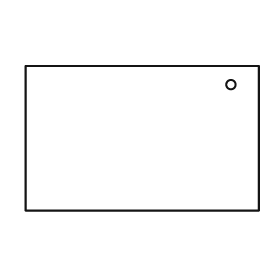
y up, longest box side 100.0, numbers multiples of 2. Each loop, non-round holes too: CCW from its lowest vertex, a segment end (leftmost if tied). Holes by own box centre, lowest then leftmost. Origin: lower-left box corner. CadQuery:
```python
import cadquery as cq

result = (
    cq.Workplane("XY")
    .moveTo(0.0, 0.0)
    .lineTo(100.0, 0.0)
    .lineTo(100.0, 62.0)
    .lineTo(0.0, 62.0)
    .close()
    .moveTo(88.0, 54.0)
    .circle(2.0)
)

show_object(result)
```